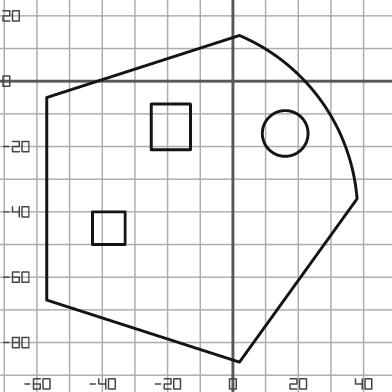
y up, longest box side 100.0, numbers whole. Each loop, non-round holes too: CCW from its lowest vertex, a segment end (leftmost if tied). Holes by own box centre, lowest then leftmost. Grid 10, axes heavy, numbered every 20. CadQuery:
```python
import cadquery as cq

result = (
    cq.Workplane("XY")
    .moveTo(2.0, -86.0)
    .lineTo(38.0, -36.0)
    .threePointArc((27.0, -6.0), (2.0, 14.0))
    .lineTo(-57.0, -5.0)
    .lineTo(-57.0, -67.0)
    .close()
    .moveTo(-43.0, -50.0)
    .lineTo(-33.0, -50.0)
    .lineTo(-33.0, -40.0)
    .lineTo(-43.0, -40.0)
    .close()
    .moveTo(16.0, -16.0)
    .circle(7.0)
    .moveTo(-25.0, -21.0)
    .lineTo(-13.0, -21.0)
    .lineTo(-13.0, -7.0)
    .lineTo(-25.0, -7.0)
    .close()
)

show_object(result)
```